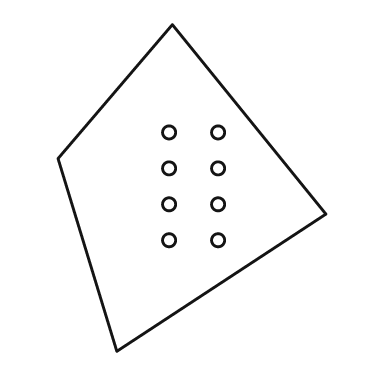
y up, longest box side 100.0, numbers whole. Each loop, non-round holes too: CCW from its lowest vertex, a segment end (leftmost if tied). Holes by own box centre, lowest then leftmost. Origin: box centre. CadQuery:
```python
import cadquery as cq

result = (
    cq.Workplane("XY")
    .moveTo(-23.0, -50.0)
    .lineTo(41.0, -8.0)
    .lineTo(-6.0, 50.0)
    .lineTo(-41.0, 9.0)
    .close()
    .moveTo(-7.0, -16.0)
    .circle(2.0)
    .moveTo(8.0, -16.0)
    .circle(2.0)
    .moveTo(-7.0, -5.0)
    .circle(2.0)
    .moveTo(8.0, -5.0)
    .circle(2.0)
    .moveTo(-7.0, 6.0)
    .circle(2.0)
    .moveTo(8.0, 6.0)
    .circle(2.0)
    .moveTo(-7.0, 17.0)
    .circle(2.0)
    .moveTo(8.0, 17.0)
    .circle(2.0)
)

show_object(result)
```